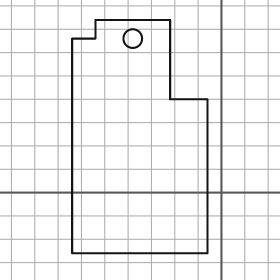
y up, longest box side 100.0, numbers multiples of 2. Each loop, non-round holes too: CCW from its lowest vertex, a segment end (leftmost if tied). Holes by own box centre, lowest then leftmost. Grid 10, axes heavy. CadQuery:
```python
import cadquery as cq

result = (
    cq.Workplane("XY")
    .moveTo(-64.0, -26.0)
    .lineTo(-6.0, -26.0)
    .lineTo(-6.0, 40.0)
    .lineTo(-22.0, 40.0)
    .lineTo(-22.0, 74.0)
    .lineTo(-54.0, 74.0)
    .lineTo(-54.0, 66.0)
    .lineTo(-64.0, 66.0)
    .close()
    .moveTo(-38.0, 66.0)
    .circle(4.0)
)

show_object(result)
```